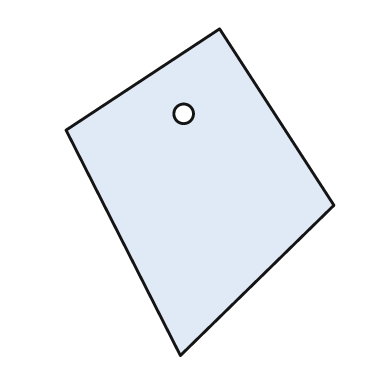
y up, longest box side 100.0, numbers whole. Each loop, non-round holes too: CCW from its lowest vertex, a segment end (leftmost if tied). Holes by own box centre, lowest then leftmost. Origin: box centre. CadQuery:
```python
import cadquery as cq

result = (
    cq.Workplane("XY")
    .moveTo(-6.0, -50.0)
    .lineTo(41.0, -4.0)
    .lineTo(6.0, 50.0)
    .lineTo(-41.0, 19.0)
    .close()
    .moveTo(-5.0, 24.0)
    .circle(3.0)
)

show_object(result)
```